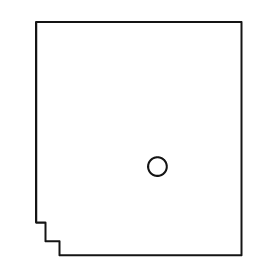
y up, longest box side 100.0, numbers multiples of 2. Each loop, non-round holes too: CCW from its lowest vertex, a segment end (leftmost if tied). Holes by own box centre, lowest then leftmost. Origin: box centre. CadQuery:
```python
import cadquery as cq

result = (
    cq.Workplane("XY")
    .moveTo(-34.0, -50.0)
    .lineTo(44.0, -50.0)
    .lineTo(44.0, 50.0)
    .lineTo(-44.0, 50.0)
    .lineTo(-44.0, -36.0)
    .lineTo(-40.0, -36.0)
    .lineTo(-40.0, -44.0)
    .lineTo(-34.0, -44.0)
    .close()
    .moveTo(8.0, -12.0)
    .circle(4.0)
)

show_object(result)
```